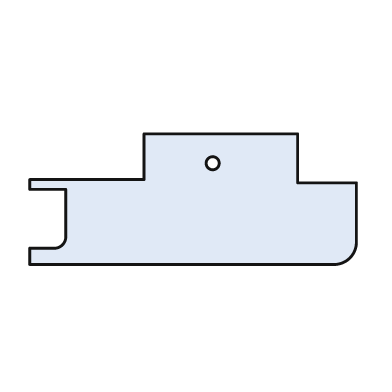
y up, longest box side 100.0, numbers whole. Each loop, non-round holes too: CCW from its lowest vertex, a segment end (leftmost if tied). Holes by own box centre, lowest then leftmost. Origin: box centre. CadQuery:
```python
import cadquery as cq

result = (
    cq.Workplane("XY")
    .moveTo(-50.0, -20.0)
    .lineTo(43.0, -20.0)
    .threePointArc((48.0, -18.0), (50.0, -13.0))
    .lineTo(50.0, 5.0)
    .lineTo(32.0, 5.0)
    .lineTo(32.0, 20.0)
    .lineTo(-15.0, 20.0)
    .lineTo(-15.0, 6.0)
    .lineTo(-50.0, 6.0)
    .lineTo(-50.0, 3.0)
    .lineTo(-39.0, 3.0)
    .lineTo(-39.0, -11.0)
    .threePointArc((-40.0, -14.0), (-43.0, -15.0))
    .lineTo(-50.0, -15.0)
    .close()
    .moveTo(6.0, 11.0)
    .circle(2.0)
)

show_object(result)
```